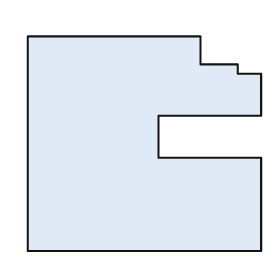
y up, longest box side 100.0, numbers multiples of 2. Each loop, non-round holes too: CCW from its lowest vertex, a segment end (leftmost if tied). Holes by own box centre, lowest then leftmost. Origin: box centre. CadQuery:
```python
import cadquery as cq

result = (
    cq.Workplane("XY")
    .moveTo(-50.0, -46.0)
    .lineTo(50.0, -46.0)
    .lineTo(50.0, -6.0)
    .lineTo(6.0, -6.0)
    .lineTo(6.0, 12.0)
    .lineTo(50.0, 12.0)
    .lineTo(50.0, 30.0)
    .lineTo(40.0, 30.0)
    .lineTo(40.0, 34.0)
    .lineTo(24.0, 34.0)
    .lineTo(24.0, 46.0)
    .lineTo(-50.0, 46.0)
    .close()
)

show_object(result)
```